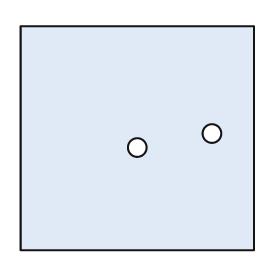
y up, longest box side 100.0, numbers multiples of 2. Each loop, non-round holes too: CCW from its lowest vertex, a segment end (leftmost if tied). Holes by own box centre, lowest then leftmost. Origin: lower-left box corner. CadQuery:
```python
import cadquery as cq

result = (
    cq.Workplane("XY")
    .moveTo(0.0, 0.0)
    .lineTo(100.0, 0.0)
    .lineTo(100.0, 96.0)
    .lineTo(0.0, 96.0)
    .close()
    .moveTo(50.0, 44.0)
    .circle(4.0)
    .moveTo(82.0, 50.0)
    .circle(4.0)
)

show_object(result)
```